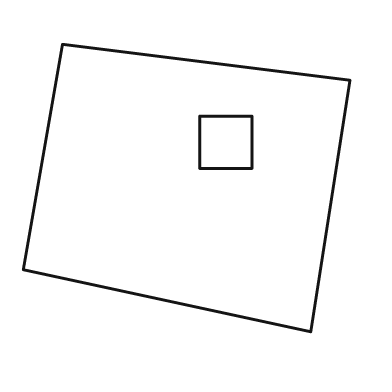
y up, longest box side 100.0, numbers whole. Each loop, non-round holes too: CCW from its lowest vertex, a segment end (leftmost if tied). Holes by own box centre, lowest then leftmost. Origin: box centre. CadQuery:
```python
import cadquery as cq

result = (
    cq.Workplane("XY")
    .moveTo(38.0, -44.0)
    .lineTo(50.0, 33.0)
    .lineTo(-38.0, 44.0)
    .lineTo(-50.0, -25.0)
    .close()
    .moveTo(4.0, 6.0)
    .lineTo(20.0, 6.0)
    .lineTo(20.0, 22.0)
    .lineTo(4.0, 22.0)
    .close()
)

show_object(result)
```